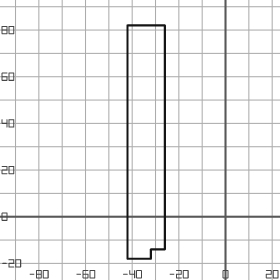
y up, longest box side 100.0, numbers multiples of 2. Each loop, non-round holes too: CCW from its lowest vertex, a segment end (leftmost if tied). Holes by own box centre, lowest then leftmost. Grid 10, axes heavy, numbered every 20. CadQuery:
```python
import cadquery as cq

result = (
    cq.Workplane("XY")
    .moveTo(-42.0, -18.0)
    .lineTo(-32.0, -18.0)
    .lineTo(-32.0, -14.0)
    .lineTo(-26.0, -14.0)
    .lineTo(-26.0, 82.0)
    .lineTo(-42.0, 82.0)
    .close()
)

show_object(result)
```